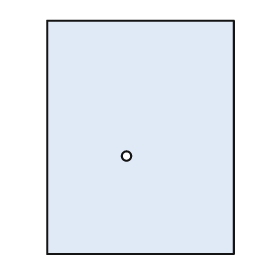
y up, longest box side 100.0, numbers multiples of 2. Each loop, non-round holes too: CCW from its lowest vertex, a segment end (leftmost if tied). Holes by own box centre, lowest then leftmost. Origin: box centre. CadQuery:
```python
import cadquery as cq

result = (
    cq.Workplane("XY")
    .moveTo(-40.0, -50.0)
    .lineTo(40.0, -50.0)
    .lineTo(40.0, 50.0)
    .lineTo(-40.0, 50.0)
    .close()
    .moveTo(-6.0, -8.0)
    .circle(2.0)
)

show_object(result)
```